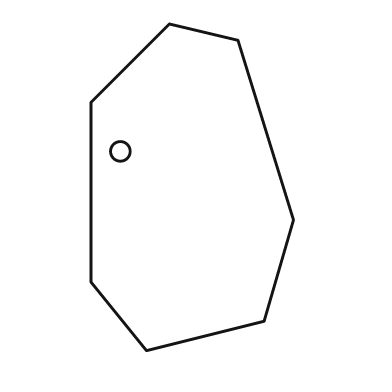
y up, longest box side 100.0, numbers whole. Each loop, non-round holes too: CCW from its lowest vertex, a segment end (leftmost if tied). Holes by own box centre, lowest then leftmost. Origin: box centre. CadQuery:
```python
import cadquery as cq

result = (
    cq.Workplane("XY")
    .moveTo(-14.0, -50.0)
    .lineTo(22.0, -41.0)
    .lineTo(31.0, -10.0)
    .lineTo(14.0, 45.0)
    .lineTo(-7.0, 50.0)
    .lineTo(-31.0, 26.0)
    .lineTo(-31.0, -29.0)
    .close()
    .moveTo(-22.0, 11.0)
    .circle(3.0)
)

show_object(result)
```